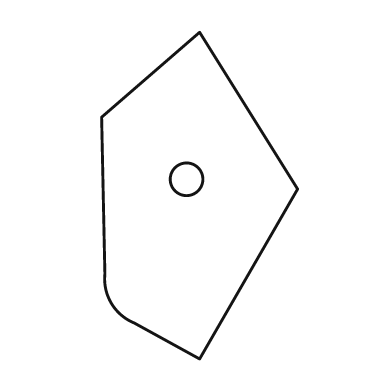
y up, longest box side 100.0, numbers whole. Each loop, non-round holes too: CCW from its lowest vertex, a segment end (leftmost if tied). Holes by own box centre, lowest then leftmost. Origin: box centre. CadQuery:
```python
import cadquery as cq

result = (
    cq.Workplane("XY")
    .moveTo(0.0, -50.0)
    .lineTo(30.0, 2.0)
    .lineTo(0.0, 50.0)
    .lineTo(-30.0, 24.0)
    .lineTo(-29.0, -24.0)
    .threePointArc((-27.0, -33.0), (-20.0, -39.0))
    .close()
    .moveTo(-4.0, 5.0)
    .circle(5.0)
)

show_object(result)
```